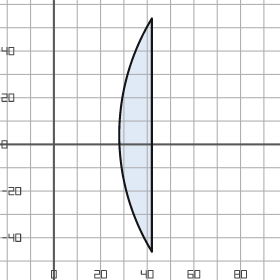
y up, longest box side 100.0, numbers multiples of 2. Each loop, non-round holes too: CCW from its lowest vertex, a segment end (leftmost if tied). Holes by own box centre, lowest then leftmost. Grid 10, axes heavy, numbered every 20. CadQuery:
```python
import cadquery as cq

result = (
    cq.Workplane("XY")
    .moveTo(42.0, -46.0)
    .lineTo(42.0, 54.0)
    .threePointArc((28.0, 4.0), (42.0, -46.0))
    .close()
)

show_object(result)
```